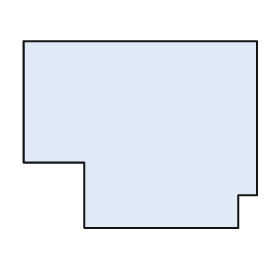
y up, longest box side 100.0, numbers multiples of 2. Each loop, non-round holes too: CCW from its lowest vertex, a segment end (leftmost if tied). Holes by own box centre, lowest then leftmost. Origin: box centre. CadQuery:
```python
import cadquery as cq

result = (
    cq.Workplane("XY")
    .moveTo(-24.0, -40.0)
    .lineTo(42.0, -40.0)
    .lineTo(42.0, -26.0)
    .lineTo(50.0, -26.0)
    .lineTo(50.0, 40.0)
    .lineTo(-50.0, 40.0)
    .lineTo(-50.0, -12.0)
    .lineTo(-24.0, -12.0)
    .close()
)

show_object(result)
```